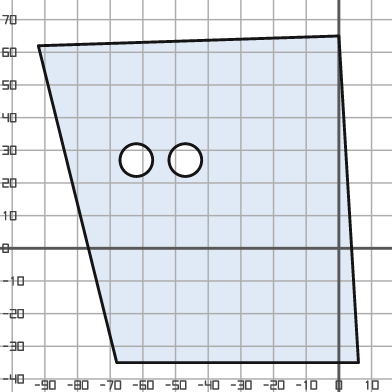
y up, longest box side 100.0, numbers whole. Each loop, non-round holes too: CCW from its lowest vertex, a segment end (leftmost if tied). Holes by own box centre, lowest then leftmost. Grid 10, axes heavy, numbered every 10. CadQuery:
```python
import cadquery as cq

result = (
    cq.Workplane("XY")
    .moveTo(-68.0, -35.0)
    .lineTo(6.0, -35.0)
    .lineTo(0.0, 65.0)
    .lineTo(-92.0, 62.0)
    .close()
    .moveTo(-62.0, 27.0)
    .circle(5.0)
    .moveTo(-47.0, 27.0)
    .circle(5.0)
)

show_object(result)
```